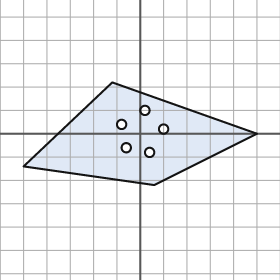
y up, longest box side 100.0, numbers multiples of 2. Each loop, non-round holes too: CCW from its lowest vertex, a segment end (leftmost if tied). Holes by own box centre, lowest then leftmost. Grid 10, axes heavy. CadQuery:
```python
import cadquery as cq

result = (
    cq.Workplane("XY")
    .moveTo(6.0, -22.0)
    .lineTo(50.0, 0.0)
    .lineTo(-12.0, 22.0)
    .lineTo(-50.0, -14.0)
    .close()
    .moveTo(4.0, -8.0)
    .circle(2.0)
    .moveTo(-6.0, -6.0)
    .circle(2.0)
    .moveTo(10.0, 2.0)
    .circle(2.0)
    .moveTo(-8.0, 4.0)
    .circle(2.0)
    .moveTo(2.0, 10.0)
    .circle(2.0)
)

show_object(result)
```